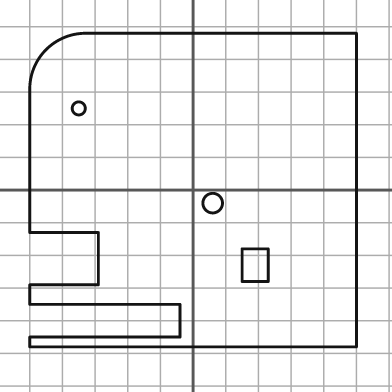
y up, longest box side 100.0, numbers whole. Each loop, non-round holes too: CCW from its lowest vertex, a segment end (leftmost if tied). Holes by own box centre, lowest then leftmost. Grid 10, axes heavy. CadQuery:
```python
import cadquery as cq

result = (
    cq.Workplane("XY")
    .moveTo(-50.0, -48.0)
    .lineTo(50.0, -48.0)
    .lineTo(50.0, 48.0)
    .lineTo(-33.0, 48.0)
    .threePointArc((-45.0, 43.0), (-50.0, 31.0))
    .lineTo(-50.0, -13.0)
    .lineTo(-29.0, -13.0)
    .lineTo(-29.0, -29.0)
    .lineTo(-50.0, -29.0)
    .lineTo(-50.0, -35.0)
    .lineTo(-4.0, -35.0)
    .lineTo(-4.0, -45.0)
    .lineTo(-50.0, -45.0)
    .close()
    .moveTo(15.0, -28.0)
    .lineTo(23.0, -28.0)
    .lineTo(23.0, -18.0)
    .lineTo(15.0, -18.0)
    .close()
    .moveTo(6.0, -4.0)
    .circle(3.0)
    .moveTo(-35.0, 25.0)
    .circle(2.0)
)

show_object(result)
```